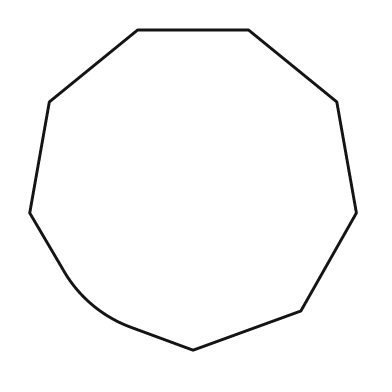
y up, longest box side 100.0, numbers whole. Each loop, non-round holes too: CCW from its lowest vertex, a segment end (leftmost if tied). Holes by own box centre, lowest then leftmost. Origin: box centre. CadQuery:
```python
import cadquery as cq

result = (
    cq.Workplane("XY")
    .moveTo(0.0, -49.0)
    .lineTo(33.0, -37.0)
    .lineTo(50.0, -7.0)
    .lineTo(44.0, 27.0)
    .lineTo(17.0, 49.0)
    .lineTo(-17.0, 49.0)
    .lineTo(-44.0, 27.0)
    .lineTo(-50.0, -7.0)
    .lineTo(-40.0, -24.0)
    .threePointArc((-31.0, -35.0), (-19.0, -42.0))
    .close()
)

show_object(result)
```